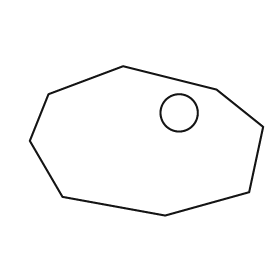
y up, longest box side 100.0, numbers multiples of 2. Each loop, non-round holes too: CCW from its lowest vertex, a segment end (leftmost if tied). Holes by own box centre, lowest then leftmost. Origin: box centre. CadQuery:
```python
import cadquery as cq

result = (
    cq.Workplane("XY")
    .moveTo(8.0, -32.0)
    .lineTo(44.0, -22.0)
    .lineTo(50.0, 6.0)
    .lineTo(30.0, 22.0)
    .lineTo(-10.0, 32.0)
    .lineTo(-42.0, 20.0)
    .lineTo(-50.0, 0.0)
    .lineTo(-36.0, -24.0)
    .close()
    .moveTo(14.0, 12.0)
    .circle(8.0)
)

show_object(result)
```